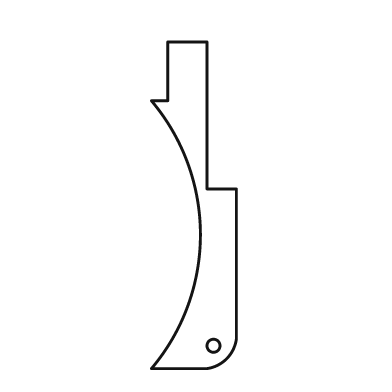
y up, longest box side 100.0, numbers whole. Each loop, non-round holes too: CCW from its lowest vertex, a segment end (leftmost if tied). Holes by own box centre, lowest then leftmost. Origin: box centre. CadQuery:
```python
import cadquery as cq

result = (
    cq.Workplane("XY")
    .moveTo(-13.0, -50.0)
    .lineTo(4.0, -50.0)
    .threePointArc((10.0, -47.0), (13.0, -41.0))
    .lineTo(13.0, 5.0)
    .lineTo(4.0, 5.0)
    .lineTo(4.0, 50.0)
    .lineTo(-8.0, 50.0)
    .lineTo(-8.0, 32.0)
    .lineTo(-13.0, 32.0)
    .threePointArc((2.0, -9.0), (-13.0, -50.0))
    .close()
    .moveTo(6.0, -43.0)
    .circle(2.0)
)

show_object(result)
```